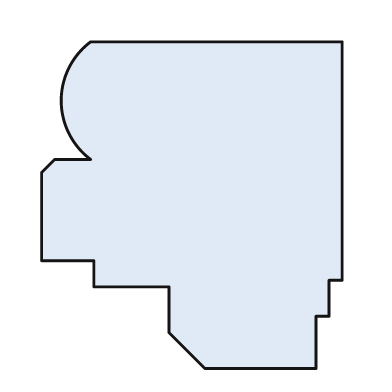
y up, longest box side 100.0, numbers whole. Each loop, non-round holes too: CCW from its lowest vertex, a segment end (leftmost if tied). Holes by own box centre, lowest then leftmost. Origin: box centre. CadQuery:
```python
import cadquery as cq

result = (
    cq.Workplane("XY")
    .moveTo(4.0, -50.0)
    .lineTo(38.0, -50.0)
    .lineTo(38.0, -34.0)
    .lineTo(42.0, -34.0)
    .lineTo(42.0, -23.0)
    .lineTo(46.0, -23.0)
    .lineTo(46.0, 50.0)
    .lineTo(-31.0, 50.0)
    .threePointArc((-40.0, 32.0), (-31.0, 14.0))
    .lineTo(-42.0, 14.0)
    .lineTo(-46.0, 10.0)
    .lineTo(-46.0, -17.0)
    .lineTo(-30.0, -17.0)
    .lineTo(-30.0, -25.0)
    .lineTo(-7.0, -25.0)
    .lineTo(-7.0, -39.0)
    .close()
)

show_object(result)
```